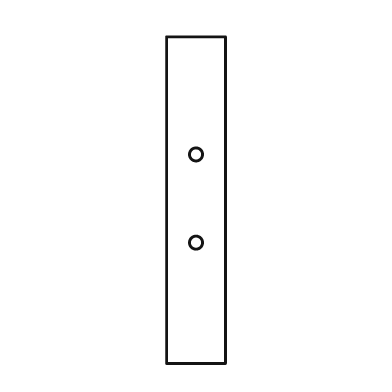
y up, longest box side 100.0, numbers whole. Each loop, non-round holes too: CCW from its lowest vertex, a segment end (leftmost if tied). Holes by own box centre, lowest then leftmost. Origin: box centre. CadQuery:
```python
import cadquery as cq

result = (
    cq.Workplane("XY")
    .moveTo(-9.0, -50.0)
    .lineTo(9.0, -50.0)
    .lineTo(9.0, 50.0)
    .lineTo(-9.0, 50.0)
    .close()
    .moveTo(0.0, -13.0)
    .circle(2.0)
    .moveTo(0.0, 14.0)
    .circle(2.0)
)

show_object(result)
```